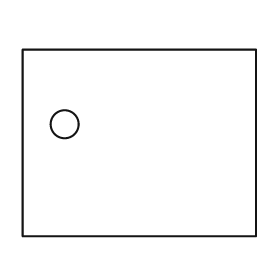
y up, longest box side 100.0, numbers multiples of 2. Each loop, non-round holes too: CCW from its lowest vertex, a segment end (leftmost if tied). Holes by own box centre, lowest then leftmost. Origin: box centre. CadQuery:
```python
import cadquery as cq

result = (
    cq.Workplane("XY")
    .moveTo(-50.0, -40.0)
    .lineTo(50.0, -40.0)
    .lineTo(50.0, 40.0)
    .lineTo(-50.0, 40.0)
    .close()
    .moveTo(-32.0, 8.0)
    .circle(6.0)
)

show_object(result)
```